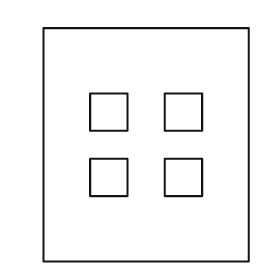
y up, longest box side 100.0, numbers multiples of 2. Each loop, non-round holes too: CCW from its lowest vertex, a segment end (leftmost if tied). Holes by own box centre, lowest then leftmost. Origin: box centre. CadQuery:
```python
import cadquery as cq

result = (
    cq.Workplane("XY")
    .moveTo(-44.0, -50.0)
    .lineTo(44.0, -50.0)
    .lineTo(44.0, 50.0)
    .lineTo(-44.0, 50.0)
    .close()
    .moveTo(-24.0, -22.0)
    .lineTo(-8.0, -22.0)
    .lineTo(-8.0, -6.0)
    .lineTo(-24.0, -6.0)
    .close()
    .moveTo(8.0, -22.0)
    .lineTo(24.0, -22.0)
    .lineTo(24.0, -6.0)
    .lineTo(8.0, -6.0)
    .close()
    .moveTo(-24.0, 6.0)
    .lineTo(-8.0, 6.0)
    .lineTo(-8.0, 22.0)
    .lineTo(-24.0, 22.0)
    .close()
    .moveTo(8.0, 6.0)
    .lineTo(24.0, 6.0)
    .lineTo(24.0, 22.0)
    .lineTo(8.0, 22.0)
    .close()
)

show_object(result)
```